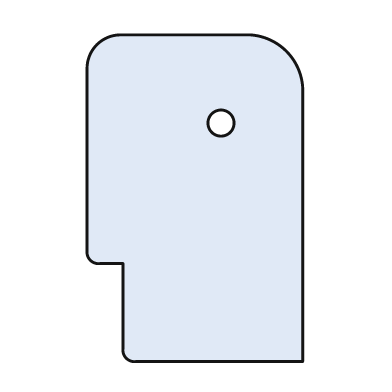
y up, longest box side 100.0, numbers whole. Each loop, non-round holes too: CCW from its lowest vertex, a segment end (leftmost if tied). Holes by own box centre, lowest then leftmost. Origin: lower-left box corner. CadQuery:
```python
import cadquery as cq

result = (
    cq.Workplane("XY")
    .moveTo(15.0, 0.0)
    .lineTo(66.0, 0.0)
    .lineTo(66.0, 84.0)
    .threePointArc((61.0, 95.0), (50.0, 100.0))
    .lineTo(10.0, 100.0)
    .threePointArc((3.0, 97.0), (0.0, 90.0))
    .lineTo(0.0, 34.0)
    .threePointArc((1.0, 31.0), (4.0, 30.0))
    .lineTo(11.0, 30.0)
    .lineTo(11.0, 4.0)
    .threePointArc((12.0, 1.0), (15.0, 0.0))
    .close()
    .moveTo(41.0, 73.0)
    .circle(4.0)
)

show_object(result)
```